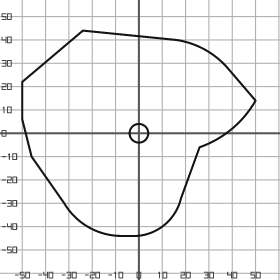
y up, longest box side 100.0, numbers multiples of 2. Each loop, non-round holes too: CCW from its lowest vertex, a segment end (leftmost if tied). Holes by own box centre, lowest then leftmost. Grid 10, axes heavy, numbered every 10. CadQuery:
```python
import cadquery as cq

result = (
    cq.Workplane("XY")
    .moveTo(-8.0, -44.0)
    .lineTo(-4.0, -44.0)
    .threePointArc((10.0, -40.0), (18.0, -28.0))
    .lineTo(26.0, -6.0)
    .threePointArc((40.0, 2.0), (50.0, 14.0))
    .lineTo(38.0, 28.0)
    .threePointArc((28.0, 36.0), (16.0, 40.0))
    .lineTo(-24.0, 44.0)
    .lineTo(-50.0, 22.0)
    .lineTo(-50.0, 6.0)
    .lineTo(-46.0, -10.0)
    .lineTo(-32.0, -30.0)
    .threePointArc((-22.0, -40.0), (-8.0, -44.0))
    .close()
    .moveTo(0.0, 0.0)
    .circle(4.0)
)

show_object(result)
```